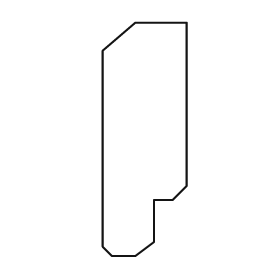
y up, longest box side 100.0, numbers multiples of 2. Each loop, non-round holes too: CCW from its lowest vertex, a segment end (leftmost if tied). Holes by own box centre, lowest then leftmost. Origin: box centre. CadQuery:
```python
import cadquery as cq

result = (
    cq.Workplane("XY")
    .moveTo(-14.0, -50.0)
    .lineTo(-4.0, -50.0)
    .lineTo(4.0, -44.0)
    .lineTo(4.0, -26.0)
    .lineTo(12.0, -26.0)
    .lineTo(18.0, -20.0)
    .lineTo(18.0, 50.0)
    .lineTo(-4.0, 50.0)
    .lineTo(-18.0, 38.0)
    .lineTo(-18.0, -46.0)
    .close()
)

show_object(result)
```